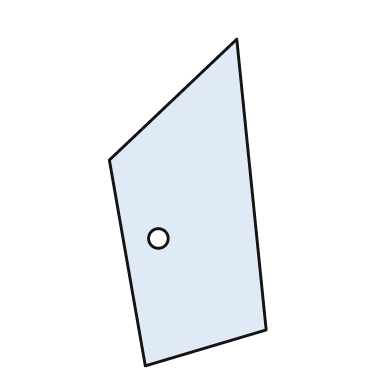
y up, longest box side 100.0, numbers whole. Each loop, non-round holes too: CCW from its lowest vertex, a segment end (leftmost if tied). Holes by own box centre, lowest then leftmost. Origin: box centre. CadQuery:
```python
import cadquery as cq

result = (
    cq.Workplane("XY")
    .moveTo(-13.0, -50.0)
    .lineTo(24.0, -39.0)
    .lineTo(15.0, 50.0)
    .lineTo(-24.0, 13.0)
    .close()
    .moveTo(-9.0, -11.0)
    .circle(3.0)
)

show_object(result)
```